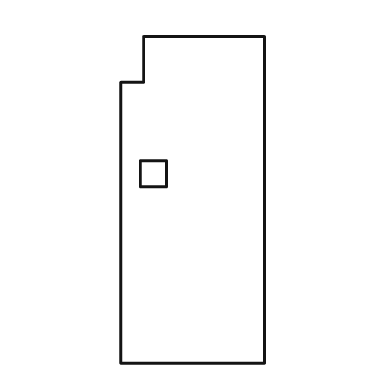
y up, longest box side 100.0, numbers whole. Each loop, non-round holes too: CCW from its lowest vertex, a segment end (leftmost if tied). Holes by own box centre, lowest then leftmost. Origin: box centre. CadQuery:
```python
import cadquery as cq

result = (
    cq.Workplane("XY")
    .moveTo(-22.0, -50.0)
    .lineTo(22.0, -50.0)
    .lineTo(22.0, 50.0)
    .lineTo(-15.0, 50.0)
    .lineTo(-15.0, 36.0)
    .lineTo(-22.0, 36.0)
    .close()
    .moveTo(-16.0, 4.0)
    .lineTo(-8.0, 4.0)
    .lineTo(-8.0, 12.0)
    .lineTo(-16.0, 12.0)
    .close()
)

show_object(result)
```